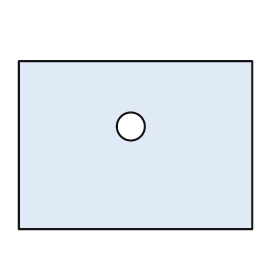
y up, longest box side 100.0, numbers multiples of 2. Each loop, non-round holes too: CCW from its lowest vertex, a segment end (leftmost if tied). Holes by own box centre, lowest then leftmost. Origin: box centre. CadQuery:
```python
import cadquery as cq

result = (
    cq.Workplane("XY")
    .moveTo(-50.0, -36.0)
    .lineTo(50.0, -36.0)
    .lineTo(50.0, 36.0)
    .lineTo(-50.0, 36.0)
    .close()
    .moveTo(-2.0, 8.0)
    .circle(6.0)
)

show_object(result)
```